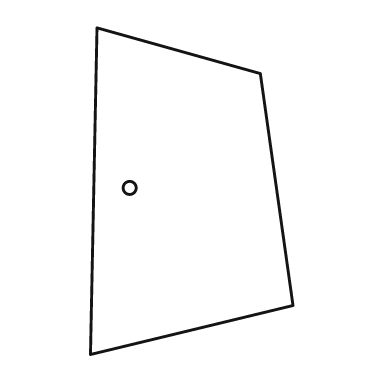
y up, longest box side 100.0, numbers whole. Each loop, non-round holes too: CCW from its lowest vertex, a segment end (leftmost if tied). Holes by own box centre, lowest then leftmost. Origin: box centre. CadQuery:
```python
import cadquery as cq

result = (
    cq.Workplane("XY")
    .moveTo(-31.0, -50.0)
    .lineTo(31.0, -35.0)
    .lineTo(21.0, 36.0)
    .lineTo(-29.0, 50.0)
    .close()
    .moveTo(-19.0, 1.0)
    .circle(2.0)
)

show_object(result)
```